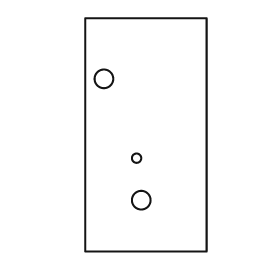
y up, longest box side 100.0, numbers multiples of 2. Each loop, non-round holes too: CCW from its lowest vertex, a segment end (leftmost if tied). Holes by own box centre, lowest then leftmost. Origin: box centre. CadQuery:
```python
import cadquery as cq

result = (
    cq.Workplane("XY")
    .moveTo(-26.0, -50.0)
    .lineTo(26.0, -50.0)
    .lineTo(26.0, 50.0)
    .lineTo(-26.0, 50.0)
    .close()
    .moveTo(-2.0, -28.0)
    .circle(4.0)
    .moveTo(-4.0, -10.0)
    .circle(2.0)
    .moveTo(-18.0, 24.0)
    .circle(4.0)
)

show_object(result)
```